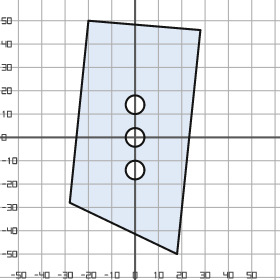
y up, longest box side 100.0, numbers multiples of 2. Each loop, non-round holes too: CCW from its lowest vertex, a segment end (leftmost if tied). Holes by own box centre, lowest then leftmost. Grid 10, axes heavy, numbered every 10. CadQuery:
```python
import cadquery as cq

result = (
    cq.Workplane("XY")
    .moveTo(18.0, -50.0)
    .lineTo(28.0, 46.0)
    .lineTo(-20.0, 50.0)
    .lineTo(-28.0, -28.0)
    .close()
    .moveTo(0.0, -14.0)
    .circle(4.0)
    .moveTo(0.0, 0.0)
    .circle(4.0)
    .moveTo(0.0, 14.0)
    .circle(4.0)
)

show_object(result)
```